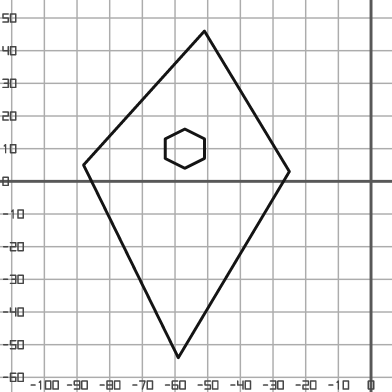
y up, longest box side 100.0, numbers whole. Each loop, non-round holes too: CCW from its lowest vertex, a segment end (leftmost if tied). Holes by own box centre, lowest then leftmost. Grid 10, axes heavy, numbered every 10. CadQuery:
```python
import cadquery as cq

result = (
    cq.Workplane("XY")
    .moveTo(-59.0, -54.0)
    .lineTo(-25.0, 3.0)
    .lineTo(-51.0, 46.0)
    .lineTo(-88.0, 5.0)
    .close()
    .moveTo(-57.0, 4.0)
    .lineTo(-51.0, 7.0)
    .lineTo(-51.0, 13.0)
    .lineTo(-57.0, 16.0)
    .lineTo(-63.0, 13.0)
    .lineTo(-63.0, 7.0)
    .close()
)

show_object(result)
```